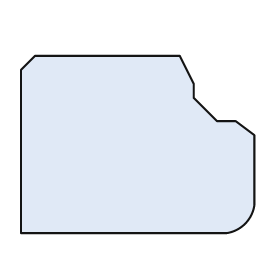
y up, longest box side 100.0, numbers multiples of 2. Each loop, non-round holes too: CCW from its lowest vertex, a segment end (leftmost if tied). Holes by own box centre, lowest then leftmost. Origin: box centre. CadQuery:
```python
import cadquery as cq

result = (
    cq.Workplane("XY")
    .moveTo(-50.0, -38.0)
    .lineTo(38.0, -38.0)
    .threePointArc((46.0, -34.0), (50.0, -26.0))
    .lineTo(50.0, 4.0)
    .lineTo(42.0, 10.0)
    .lineTo(34.0, 10.0)
    .lineTo(24.0, 20.0)
    .lineTo(24.0, 26.0)
    .lineTo(18.0, 38.0)
    .lineTo(-44.0, 38.0)
    .lineTo(-50.0, 32.0)
    .close()
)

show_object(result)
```